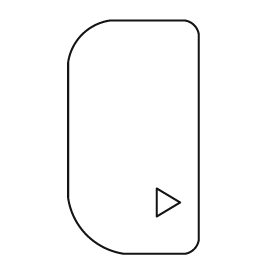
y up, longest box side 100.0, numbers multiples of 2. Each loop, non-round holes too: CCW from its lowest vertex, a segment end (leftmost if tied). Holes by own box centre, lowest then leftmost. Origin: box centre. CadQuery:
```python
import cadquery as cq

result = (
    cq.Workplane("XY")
    .moveTo(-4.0, -50.0)
    .lineTo(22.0, -50.0)
    .threePointArc((26.0, -48.0), (28.0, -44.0))
    .lineTo(28.0, 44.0)
    .threePointArc((26.0, 48.0), (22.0, 50.0))
    .lineTo(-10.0, 50.0)
    .threePointArc((-22.0, 44.0), (-28.0, 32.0))
    .lineTo(-28.0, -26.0)
    .threePointArc((-20.0, -42.0), (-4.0, -50.0))
    .close()
    .moveTo(10.0, -34.0)
    .lineTo(20.0, -28.0)
    .lineTo(10.0, -22.0)
    .close()
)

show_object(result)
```